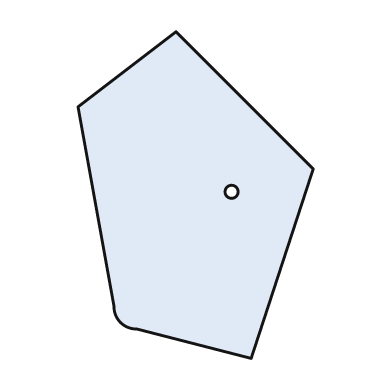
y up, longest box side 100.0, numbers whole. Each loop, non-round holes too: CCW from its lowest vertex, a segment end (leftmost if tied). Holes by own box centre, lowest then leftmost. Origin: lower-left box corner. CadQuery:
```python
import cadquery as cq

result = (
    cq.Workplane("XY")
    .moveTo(53.0, 0.0)
    .lineTo(72.0, 58.0)
    .lineTo(30.0, 100.0)
    .lineTo(0.0, 77.0)
    .lineTo(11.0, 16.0)
    .threePointArc((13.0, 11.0), (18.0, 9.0))
    .close()
    .moveTo(47.0, 51.0)
    .circle(2.0)
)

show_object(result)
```